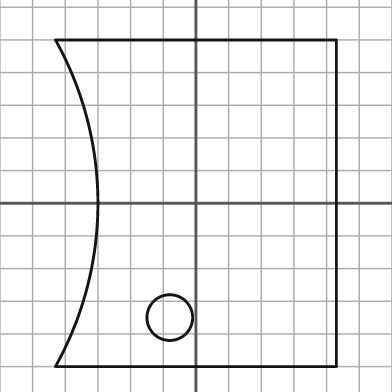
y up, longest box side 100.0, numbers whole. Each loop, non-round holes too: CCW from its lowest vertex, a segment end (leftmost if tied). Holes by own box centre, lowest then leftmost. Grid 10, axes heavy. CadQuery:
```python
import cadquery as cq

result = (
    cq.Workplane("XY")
    .moveTo(-43.0, -50.0)
    .lineTo(43.0, -50.0)
    .lineTo(43.0, 50.0)
    .lineTo(-43.0, 50.0)
    .threePointArc((-30.0, 0.0), (-43.0, -50.0))
    .close()
    .moveTo(-8.0, -35.0)
    .circle(7.0)
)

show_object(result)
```